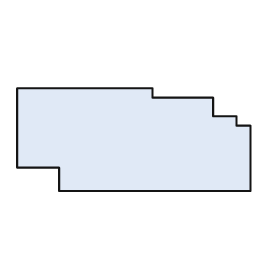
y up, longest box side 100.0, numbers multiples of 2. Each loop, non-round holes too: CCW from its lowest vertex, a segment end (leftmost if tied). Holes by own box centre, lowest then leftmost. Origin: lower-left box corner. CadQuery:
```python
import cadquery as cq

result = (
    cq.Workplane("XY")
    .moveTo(18.0, 0.0)
    .lineTo(100.0, 0.0)
    .lineTo(100.0, 28.0)
    .lineTo(94.0, 28.0)
    .lineTo(94.0, 32.0)
    .lineTo(84.0, 32.0)
    .lineTo(84.0, 40.0)
    .lineTo(58.0, 40.0)
    .lineTo(58.0, 44.0)
    .lineTo(0.0, 44.0)
    .lineTo(0.0, 10.0)
    .lineTo(18.0, 10.0)
    .close()
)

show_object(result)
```